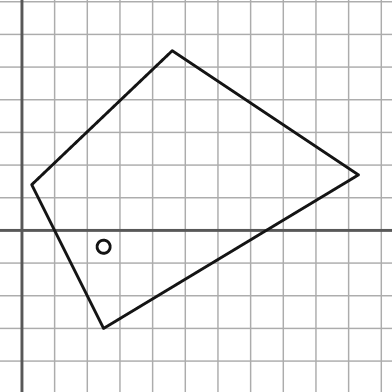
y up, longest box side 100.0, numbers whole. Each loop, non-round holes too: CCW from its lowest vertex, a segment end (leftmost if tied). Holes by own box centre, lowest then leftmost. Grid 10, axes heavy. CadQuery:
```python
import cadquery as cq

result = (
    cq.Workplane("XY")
    .moveTo(25.0, -30.0)
    .lineTo(103.0, 17.0)
    .lineTo(46.0, 55.0)
    .lineTo(3.0, 14.0)
    .close()
    .moveTo(25.0, -5.0)
    .circle(2.0)
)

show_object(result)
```